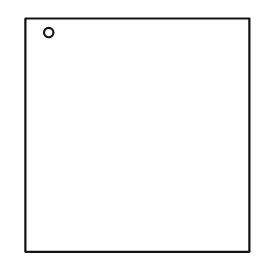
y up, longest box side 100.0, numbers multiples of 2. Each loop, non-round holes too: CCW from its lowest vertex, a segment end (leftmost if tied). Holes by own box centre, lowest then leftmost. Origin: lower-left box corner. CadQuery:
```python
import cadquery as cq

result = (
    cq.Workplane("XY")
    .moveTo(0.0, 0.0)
    .lineTo(96.0, 0.0)
    .lineTo(96.0, 100.0)
    .lineTo(0.0, 100.0)
    .close()
    .moveTo(10.0, 94.0)
    .circle(2.0)
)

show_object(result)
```